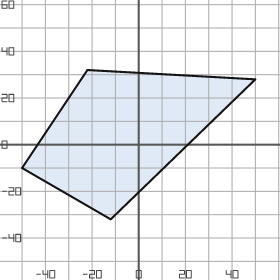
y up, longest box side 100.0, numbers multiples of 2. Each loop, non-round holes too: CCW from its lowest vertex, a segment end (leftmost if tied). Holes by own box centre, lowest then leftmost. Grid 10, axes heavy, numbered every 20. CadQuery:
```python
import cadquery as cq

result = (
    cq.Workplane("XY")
    .moveTo(-12.0, -32.0)
    .lineTo(50.0, 28.0)
    .lineTo(-22.0, 32.0)
    .lineTo(-50.0, -10.0)
    .close()
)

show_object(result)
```